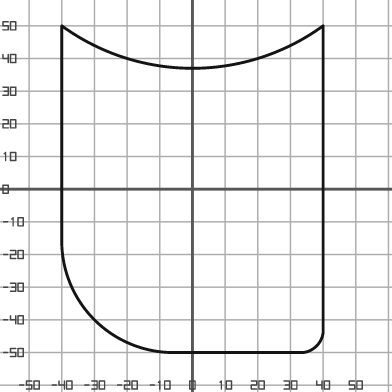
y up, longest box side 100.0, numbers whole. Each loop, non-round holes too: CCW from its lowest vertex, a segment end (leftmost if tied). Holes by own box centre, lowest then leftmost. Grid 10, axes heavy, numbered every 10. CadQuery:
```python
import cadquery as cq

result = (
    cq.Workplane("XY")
    .moveTo(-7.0, -50.0)
    .lineTo(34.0, -50.0)
    .threePointArc((38.0, -48.0), (40.0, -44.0))
    .lineTo(40.0, 50.0)
    .threePointArc((0.0, 37.0), (-40.0, 50.0))
    .lineTo(-40.0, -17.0)
    .threePointArc((-30.0, -40.0), (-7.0, -50.0))
    .close()
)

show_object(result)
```